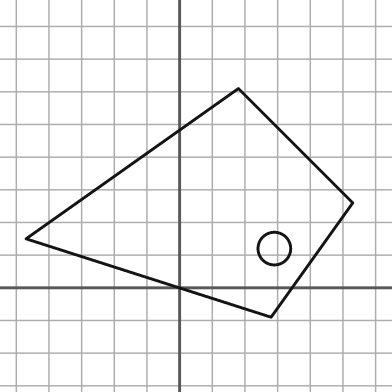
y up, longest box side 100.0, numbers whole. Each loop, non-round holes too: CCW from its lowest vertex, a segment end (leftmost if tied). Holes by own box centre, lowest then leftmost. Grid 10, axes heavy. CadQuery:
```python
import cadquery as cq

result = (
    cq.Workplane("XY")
    .moveTo(28.0, -9.0)
    .lineTo(53.0, 26.0)
    .lineTo(18.0, 61.0)
    .lineTo(-47.0, 15.0)
    .close()
    .moveTo(29.0, 12.0)
    .circle(5.0)
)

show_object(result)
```